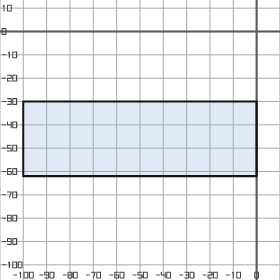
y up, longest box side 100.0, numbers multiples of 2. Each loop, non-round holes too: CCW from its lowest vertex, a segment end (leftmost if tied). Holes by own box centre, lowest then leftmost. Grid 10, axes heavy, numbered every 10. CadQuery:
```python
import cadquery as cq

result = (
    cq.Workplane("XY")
    .moveTo(-100.0, -62.0)
    .lineTo(0.0, -62.0)
    .lineTo(0.0, -30.0)
    .lineTo(-100.0, -30.0)
    .close()
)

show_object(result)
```